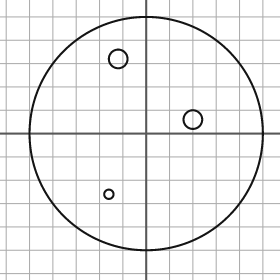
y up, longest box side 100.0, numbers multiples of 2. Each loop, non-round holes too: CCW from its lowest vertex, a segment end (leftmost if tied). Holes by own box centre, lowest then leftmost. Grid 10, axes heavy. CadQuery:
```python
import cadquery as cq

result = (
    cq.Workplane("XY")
    .moveTo(0.0, 0.0)
    .circle(50.0)
    .moveTo(-16.0, -26.0)
    .circle(2.0)
    .moveTo(20.0, 6.0)
    .circle(4.0)
    .moveTo(-12.0, 32.0)
    .circle(4.0)
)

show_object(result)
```